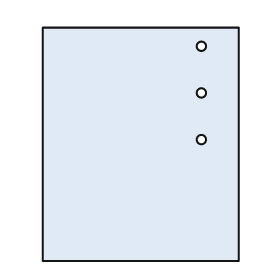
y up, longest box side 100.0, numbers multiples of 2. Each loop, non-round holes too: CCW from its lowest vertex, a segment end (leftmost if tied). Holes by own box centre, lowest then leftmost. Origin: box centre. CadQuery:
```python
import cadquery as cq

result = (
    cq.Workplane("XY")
    .moveTo(-42.0, -50.0)
    .lineTo(42.0, -50.0)
    .lineTo(42.0, 50.0)
    .lineTo(-42.0, 50.0)
    .close()
    .moveTo(26.0, 2.0)
    .circle(2.0)
    .moveTo(26.0, 22.0)
    .circle(2.0)
    .moveTo(26.0, 42.0)
    .circle(2.0)
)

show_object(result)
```